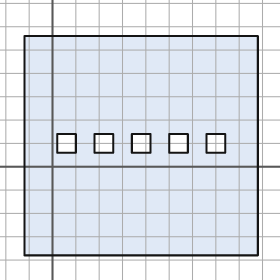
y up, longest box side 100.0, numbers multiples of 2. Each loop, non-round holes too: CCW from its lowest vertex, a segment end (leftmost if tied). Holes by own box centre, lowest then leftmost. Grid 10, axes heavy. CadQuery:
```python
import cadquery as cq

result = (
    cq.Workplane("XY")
    .moveTo(-12.0, -38.0)
    .lineTo(88.0, -38.0)
    .lineTo(88.0, 56.0)
    .lineTo(-12.0, 56.0)
    .close()
    .moveTo(2.0, 6.0)
    .lineTo(10.0, 6.0)
    .lineTo(10.0, 14.0)
    .lineTo(2.0, 14.0)
    .close()
    .moveTo(18.0, 6.0)
    .lineTo(26.0, 6.0)
    .lineTo(26.0, 14.0)
    .lineTo(18.0, 14.0)
    .close()
    .moveTo(34.0, 6.0)
    .lineTo(42.0, 6.0)
    .lineTo(42.0, 14.0)
    .lineTo(34.0, 14.0)
    .close()
    .moveTo(50.0, 6.0)
    .lineTo(58.0, 6.0)
    .lineTo(58.0, 14.0)
    .lineTo(50.0, 14.0)
    .close()
    .moveTo(66.0, 6.0)
    .lineTo(74.0, 6.0)
    .lineTo(74.0, 14.0)
    .lineTo(66.0, 14.0)
    .close()
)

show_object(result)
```